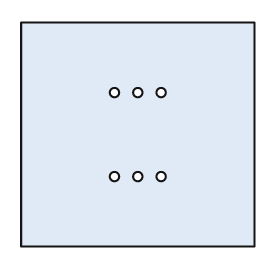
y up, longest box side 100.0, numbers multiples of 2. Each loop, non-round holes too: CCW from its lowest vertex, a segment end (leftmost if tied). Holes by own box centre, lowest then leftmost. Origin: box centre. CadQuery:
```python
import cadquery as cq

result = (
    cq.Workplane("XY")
    .moveTo(-50.0, -48.0)
    .lineTo(50.0, -48.0)
    .lineTo(50.0, 48.0)
    .lineTo(-50.0, 48.0)
    .close()
    .moveTo(-10.0, -18.0)
    .circle(2.0)
    .moveTo(0.0, -18.0)
    .circle(2.0)
    .moveTo(10.0, -18.0)
    .circle(2.0)
    .moveTo(-10.0, 18.0)
    .circle(2.0)
    .moveTo(0.0, 18.0)
    .circle(2.0)
    .moveTo(10.0, 18.0)
    .circle(2.0)
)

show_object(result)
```